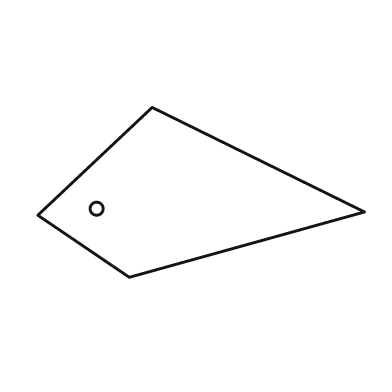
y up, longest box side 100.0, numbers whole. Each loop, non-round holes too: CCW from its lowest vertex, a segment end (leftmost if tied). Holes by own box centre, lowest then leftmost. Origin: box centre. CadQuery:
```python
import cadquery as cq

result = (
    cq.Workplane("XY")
    .moveTo(-22.0, -26.0)
    .lineTo(50.0, -6.0)
    .lineTo(-15.0, 26.0)
    .lineTo(-50.0, -7.0)
    .close()
    .moveTo(-32.0, -5.0)
    .circle(2.0)
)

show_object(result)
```